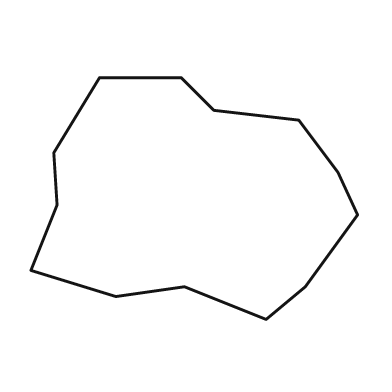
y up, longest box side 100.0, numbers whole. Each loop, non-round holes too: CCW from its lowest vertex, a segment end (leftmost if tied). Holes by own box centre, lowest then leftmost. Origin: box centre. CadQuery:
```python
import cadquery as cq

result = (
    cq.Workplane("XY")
    .moveTo(22.0, -37.0)
    .lineTo(34.0, -27.0)
    .lineTo(50.0, -5.0)
    .lineTo(44.0, 8.0)
    .lineTo(32.0, 24.0)
    .lineTo(6.0, 27.0)
    .lineTo(-4.0, 37.0)
    .lineTo(-29.0, 37.0)
    .lineTo(-43.0, 14.0)
    .lineTo(-42.0, -2.0)
    .lineTo(-50.0, -22.0)
    .lineTo(-24.0, -30.0)
    .lineTo(-3.0, -27.0)
    .close()
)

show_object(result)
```